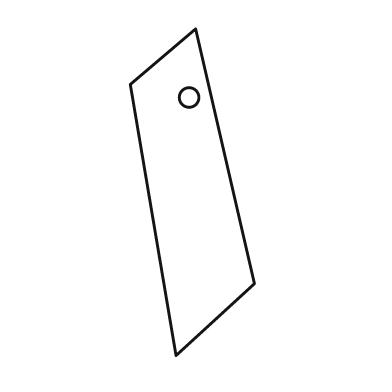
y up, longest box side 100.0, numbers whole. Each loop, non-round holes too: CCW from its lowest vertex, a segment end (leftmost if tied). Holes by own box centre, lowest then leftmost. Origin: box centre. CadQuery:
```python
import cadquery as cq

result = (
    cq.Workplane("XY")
    .moveTo(-5.0, -50.0)
    .lineTo(19.0, -28.0)
    .lineTo(1.0, 50.0)
    .lineTo(-19.0, 33.0)
    .close()
    .moveTo(-1.0, 29.0)
    .circle(3.0)
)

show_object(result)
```